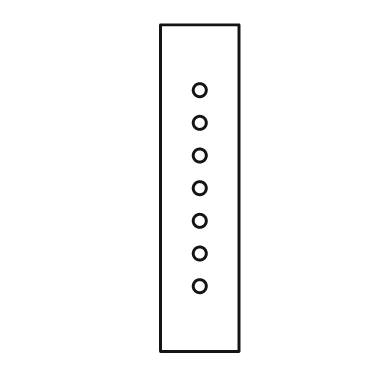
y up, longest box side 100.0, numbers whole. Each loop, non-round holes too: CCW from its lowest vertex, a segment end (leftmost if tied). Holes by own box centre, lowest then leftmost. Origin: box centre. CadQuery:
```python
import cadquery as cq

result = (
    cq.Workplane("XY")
    .moveTo(-12.0, -50.0)
    .lineTo(12.0, -50.0)
    .lineTo(12.0, 50.0)
    .lineTo(-12.0, 50.0)
    .close()
    .moveTo(0.0, -30.0)
    .circle(2.0)
    .moveTo(0.0, -20.0)
    .circle(2.0)
    .moveTo(0.0, -10.0)
    .circle(2.0)
    .moveTo(0.0, 0.0)
    .circle(2.0)
    .moveTo(0.0, 10.0)
    .circle(2.0)
    .moveTo(0.0, 20.0)
    .circle(2.0)
    .moveTo(0.0, 30.0)
    .circle(2.0)
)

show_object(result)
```